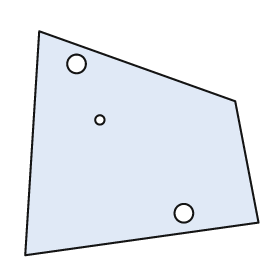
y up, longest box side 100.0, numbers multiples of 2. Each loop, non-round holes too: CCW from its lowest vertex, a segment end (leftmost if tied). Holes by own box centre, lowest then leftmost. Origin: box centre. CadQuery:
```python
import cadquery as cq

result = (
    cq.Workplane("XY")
    .moveTo(-50.0, -48.0)
    .lineTo(50.0, -34.0)
    .lineTo(40.0, 18.0)
    .lineTo(-44.0, 48.0)
    .close()
    .moveTo(18.0, -30.0)
    .circle(4.0)
    .moveTo(-18.0, 10.0)
    .circle(2.0)
    .moveTo(-28.0, 34.0)
    .circle(4.0)
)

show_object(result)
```